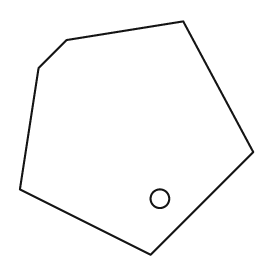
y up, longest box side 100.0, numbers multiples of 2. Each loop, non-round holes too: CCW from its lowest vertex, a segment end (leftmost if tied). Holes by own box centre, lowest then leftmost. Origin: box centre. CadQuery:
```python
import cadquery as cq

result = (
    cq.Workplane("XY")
    .moveTo(6.0, -50.0)
    .lineTo(50.0, -6.0)
    .lineTo(20.0, 50.0)
    .lineTo(-30.0, 42.0)
    .lineTo(-42.0, 30.0)
    .lineTo(-50.0, -22.0)
    .close()
    .moveTo(10.0, -26.0)
    .circle(4.0)
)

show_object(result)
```